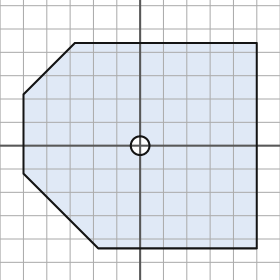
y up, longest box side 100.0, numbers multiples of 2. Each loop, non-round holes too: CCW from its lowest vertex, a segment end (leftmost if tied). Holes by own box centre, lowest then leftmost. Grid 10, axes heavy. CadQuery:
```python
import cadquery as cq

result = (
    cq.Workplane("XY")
    .moveTo(-18.0, -44.0)
    .lineTo(50.0, -44.0)
    .lineTo(50.0, 44.0)
    .lineTo(-28.0, 44.0)
    .lineTo(-50.0, 22.0)
    .lineTo(-50.0, -12.0)
    .close()
    .moveTo(0.0, 0.0)
    .circle(4.0)
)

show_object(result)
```